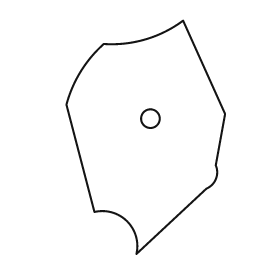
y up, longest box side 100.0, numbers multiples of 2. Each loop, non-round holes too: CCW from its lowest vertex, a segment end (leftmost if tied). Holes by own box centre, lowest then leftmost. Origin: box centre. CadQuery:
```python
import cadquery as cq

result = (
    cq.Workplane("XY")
    .moveTo(-4.0, -50.0)
    .lineTo(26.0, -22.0)
    .threePointArc((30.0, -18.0), (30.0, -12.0))
    .lineTo(34.0, 10.0)
    .lineTo(16.0, 50.0)
    .threePointArc((0.0, 42.0), (-18.0, 40.0))
    .threePointArc((-28.0, 28.0), (-34.0, 14.0))
    .lineTo(-22.0, -32.0)
    .threePointArc((-8.0, -36.0), (-4.0, -50.0))
    .close()
    .moveTo(2.0, 8.0)
    .circle(4.0)
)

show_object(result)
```